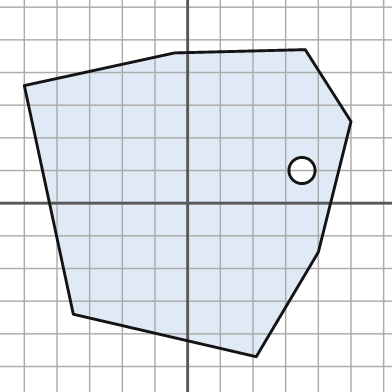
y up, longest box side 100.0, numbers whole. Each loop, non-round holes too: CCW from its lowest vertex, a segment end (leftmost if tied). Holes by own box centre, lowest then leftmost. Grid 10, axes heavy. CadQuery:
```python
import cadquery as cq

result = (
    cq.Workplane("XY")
    .moveTo(21.0, -47.0)
    .lineTo(40.0, -15.0)
    .lineTo(50.0, 25.0)
    .lineTo(36.0, 47.0)
    .lineTo(-4.0, 46.0)
    .lineTo(-50.0, 36.0)
    .lineTo(-35.0, -34.0)
    .close()
    .moveTo(35.0, 10.0)
    .circle(4.0)
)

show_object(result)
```